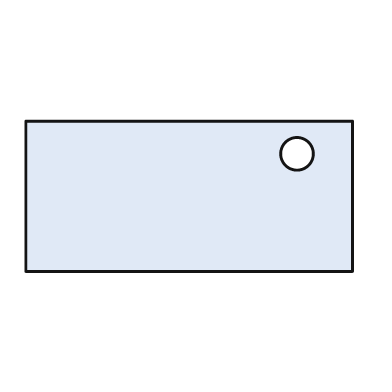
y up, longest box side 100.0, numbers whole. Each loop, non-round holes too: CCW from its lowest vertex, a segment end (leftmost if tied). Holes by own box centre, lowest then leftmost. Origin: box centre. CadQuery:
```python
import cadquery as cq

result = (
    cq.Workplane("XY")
    .moveTo(-50.0, -23.0)
    .lineTo(50.0, -23.0)
    .lineTo(50.0, 23.0)
    .lineTo(-50.0, 23.0)
    .close()
    .moveTo(33.0, 13.0)
    .circle(5.0)
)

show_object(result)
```